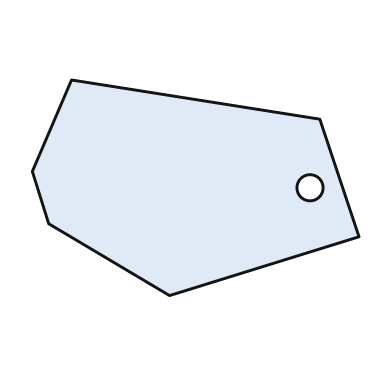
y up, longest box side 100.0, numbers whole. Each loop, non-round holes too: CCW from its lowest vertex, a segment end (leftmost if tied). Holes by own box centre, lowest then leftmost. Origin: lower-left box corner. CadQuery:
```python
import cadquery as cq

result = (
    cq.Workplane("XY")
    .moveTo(42.0, 0.0)
    .lineTo(100.0, 18.0)
    .lineTo(88.0, 54.0)
    .lineTo(12.0, 66.0)
    .lineTo(0.0, 38.0)
    .lineTo(5.0, 22.0)
    .close()
    .moveTo(85.0, 33.0)
    .circle(4.0)
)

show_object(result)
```